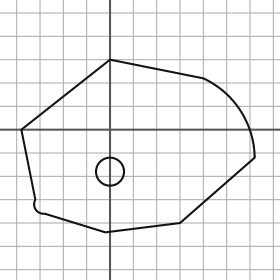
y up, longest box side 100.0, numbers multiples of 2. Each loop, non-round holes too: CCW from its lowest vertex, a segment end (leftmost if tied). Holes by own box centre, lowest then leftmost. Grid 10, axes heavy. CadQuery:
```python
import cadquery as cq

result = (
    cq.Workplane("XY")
    .moveTo(-2.0, -44.0)
    .lineTo(30.0, -40.0)
    .lineTo(62.0, -12.0)
    .threePointArc((56.0, 8.0), (40.0, 22.0))
    .lineTo(0.0, 30.0)
    .lineTo(-38.0, 0.0)
    .lineTo(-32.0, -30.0)
    .threePointArc((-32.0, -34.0), (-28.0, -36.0))
    .close()
    .moveTo(0.0, -18.0)
    .circle(6.0)
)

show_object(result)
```